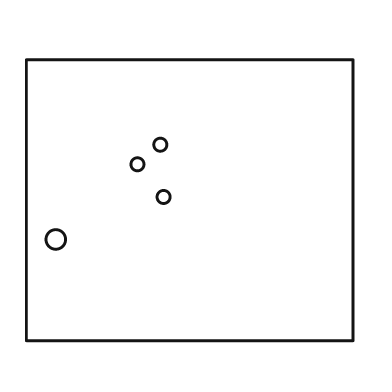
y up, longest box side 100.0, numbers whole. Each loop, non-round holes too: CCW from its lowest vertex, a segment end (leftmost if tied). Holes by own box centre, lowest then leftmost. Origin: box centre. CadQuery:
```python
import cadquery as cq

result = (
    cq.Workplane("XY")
    .moveTo(-50.0, -43.0)
    .lineTo(50.0, -43.0)
    .lineTo(50.0, 43.0)
    .lineTo(-50.0, 43.0)
    .close()
    .moveTo(-41.0, -12.0)
    .circle(3.0)
    .moveTo(-8.0, 1.0)
    .circle(2.0)
    .moveTo(-16.0, 11.0)
    .circle(2.0)
    .moveTo(-9.0, 17.0)
    .circle(2.0)
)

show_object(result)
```